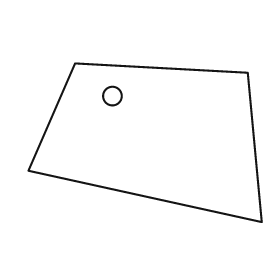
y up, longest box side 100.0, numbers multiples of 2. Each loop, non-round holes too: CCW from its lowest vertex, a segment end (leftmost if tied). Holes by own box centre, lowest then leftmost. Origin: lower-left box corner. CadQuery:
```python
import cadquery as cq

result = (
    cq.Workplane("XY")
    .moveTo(100.0, 0.0)
    .lineTo(94.0, 64.0)
    .lineTo(20.0, 68.0)
    .lineTo(0.0, 22.0)
    .close()
    .moveTo(36.0, 54.0)
    .circle(4.0)
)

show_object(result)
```